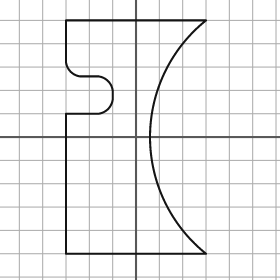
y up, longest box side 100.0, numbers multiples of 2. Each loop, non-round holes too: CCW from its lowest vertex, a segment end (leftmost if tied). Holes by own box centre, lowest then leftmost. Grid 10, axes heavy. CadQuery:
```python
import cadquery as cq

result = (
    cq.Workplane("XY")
    .moveTo(-30.0, -50.0)
    .lineTo(30.0, -50.0)
    .threePointArc((6.0, 0.0), (30.0, 50.0))
    .lineTo(-30.0, 50.0)
    .lineTo(-30.0, 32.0)
    .threePointArc((-28.0, 28.0), (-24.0, 26.0))
    .lineTo(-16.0, 26.0)
    .threePointArc((-12.0, 24.0), (-10.0, 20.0))
    .lineTo(-10.0, 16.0)
    .threePointArc((-12.0, 12.0), (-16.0, 10.0))
    .lineTo(-30.0, 10.0)
    .close()
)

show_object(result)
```